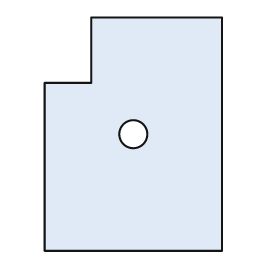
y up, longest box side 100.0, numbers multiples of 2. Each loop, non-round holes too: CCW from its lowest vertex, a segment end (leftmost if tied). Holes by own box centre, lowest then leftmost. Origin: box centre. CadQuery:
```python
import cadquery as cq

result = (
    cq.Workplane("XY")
    .moveTo(-38.0, -50.0)
    .lineTo(38.0, -50.0)
    .lineTo(38.0, 50.0)
    .lineTo(-18.0, 50.0)
    .lineTo(-18.0, 22.0)
    .lineTo(-38.0, 22.0)
    .close()
    .moveTo(0.0, 0.0)
    .circle(6.0)
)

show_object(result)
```